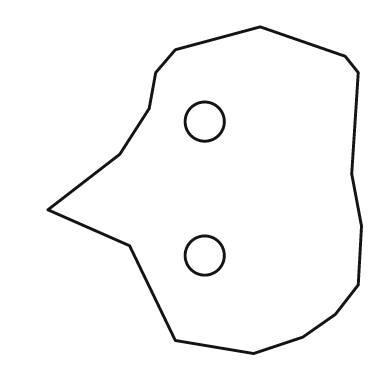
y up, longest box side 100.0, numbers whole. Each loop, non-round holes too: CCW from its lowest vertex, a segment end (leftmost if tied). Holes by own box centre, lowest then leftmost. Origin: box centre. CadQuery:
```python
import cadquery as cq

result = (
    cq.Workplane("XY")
    .moveTo(15.0, -50.0)
    .lineTo(30.0, -45.0)
    .lineTo(40.0, -38.0)
    .lineTo(47.0, -29.0)
    .lineTo(48.0, -11.0)
    .lineTo(45.0, 5.0)
    .lineTo(47.0, 36.0)
    .lineTo(43.0, 41.0)
    .lineTo(17.0, 50.0)
    .lineTo(-9.0, 43.0)
    .lineTo(-15.0, 36.0)
    .lineTo(-17.0, 25.0)
    .lineTo(-26.0, 11.0)
    .lineTo(-48.0, -6.0)
    .lineTo(-23.0, -17.0)
    .lineTo(-9.0, -46.0)
    .close()
    .moveTo(0.0, -20.0)
    .circle(6.0)
    .moveTo(0.0, 21.0)
    .circle(6.0)
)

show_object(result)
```